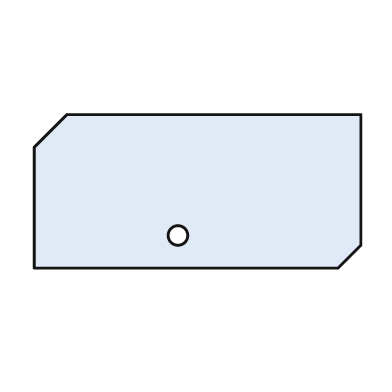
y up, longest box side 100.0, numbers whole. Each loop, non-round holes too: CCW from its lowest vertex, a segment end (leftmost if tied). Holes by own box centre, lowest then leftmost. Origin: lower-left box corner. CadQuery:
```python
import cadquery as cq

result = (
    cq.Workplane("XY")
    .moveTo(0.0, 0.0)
    .lineTo(93.0, 0.0)
    .lineTo(100.0, 7.0)
    .lineTo(100.0, 47.0)
    .lineTo(10.0, 47.0)
    .lineTo(0.0, 37.0)
    .close()
    .moveTo(44.0, 10.0)
    .circle(3.0)
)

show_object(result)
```